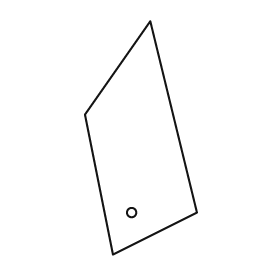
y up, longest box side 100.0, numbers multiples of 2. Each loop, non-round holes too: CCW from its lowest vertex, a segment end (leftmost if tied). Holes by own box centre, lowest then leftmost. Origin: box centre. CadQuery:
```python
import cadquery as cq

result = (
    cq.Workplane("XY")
    .moveTo(-12.0, -50.0)
    .lineTo(24.0, -32.0)
    .lineTo(4.0, 50.0)
    .lineTo(-24.0, 10.0)
    .close()
    .moveTo(-4.0, -32.0)
    .circle(2.0)
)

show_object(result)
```